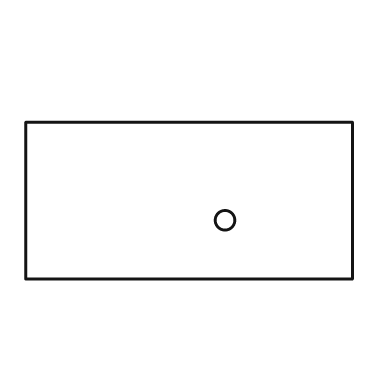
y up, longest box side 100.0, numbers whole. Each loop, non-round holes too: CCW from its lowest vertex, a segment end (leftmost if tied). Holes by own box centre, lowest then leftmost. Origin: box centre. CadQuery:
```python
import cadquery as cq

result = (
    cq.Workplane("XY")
    .moveTo(-50.0, -24.0)
    .lineTo(50.0, -24.0)
    .lineTo(50.0, 24.0)
    .lineTo(-50.0, 24.0)
    .close()
    .moveTo(11.0, -6.0)
    .circle(3.0)
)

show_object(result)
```